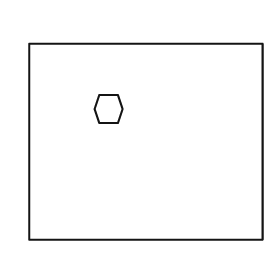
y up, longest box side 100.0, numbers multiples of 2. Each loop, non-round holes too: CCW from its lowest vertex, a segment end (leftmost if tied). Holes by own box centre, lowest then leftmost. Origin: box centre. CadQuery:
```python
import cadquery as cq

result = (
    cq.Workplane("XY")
    .moveTo(-50.0, -42.0)
    .lineTo(50.0, -42.0)
    .lineTo(50.0, 42.0)
    .lineTo(-50.0, 42.0)
    .close()
    .moveTo(-20.0, 8.0)
    .lineTo(-12.0, 8.0)
    .lineTo(-10.0, 14.0)
    .lineTo(-12.0, 20.0)
    .lineTo(-20.0, 20.0)
    .lineTo(-22.0, 14.0)
    .close()
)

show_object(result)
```